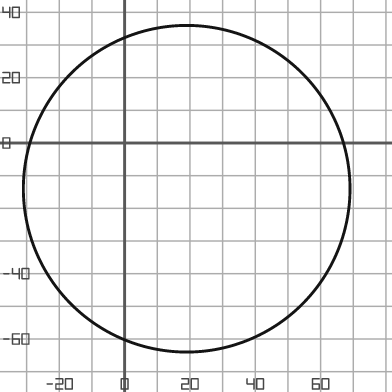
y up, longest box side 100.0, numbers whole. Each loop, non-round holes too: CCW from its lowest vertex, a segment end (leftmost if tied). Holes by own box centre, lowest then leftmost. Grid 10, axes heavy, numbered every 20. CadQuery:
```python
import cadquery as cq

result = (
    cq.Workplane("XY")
    .moveTo(19.0, -14.0)
    .circle(50.0)
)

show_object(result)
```